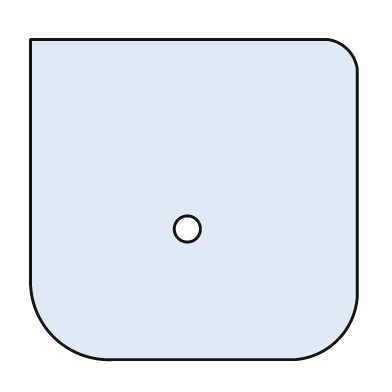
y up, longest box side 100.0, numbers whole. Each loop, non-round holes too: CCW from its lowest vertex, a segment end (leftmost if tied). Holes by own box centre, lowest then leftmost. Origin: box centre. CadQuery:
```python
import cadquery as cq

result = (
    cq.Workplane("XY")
    .moveTo(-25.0, -49.0)
    .lineTo(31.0, -49.0)
    .threePointArc((44.0, -43.0), (50.0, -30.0))
    .lineTo(50.0, 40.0)
    .threePointArc((47.0, 46.0), (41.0, 49.0))
    .lineTo(-50.0, 49.0)
    .lineTo(-50.0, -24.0)
    .threePointArc((-43.0, -42.0), (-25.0, -49.0))
    .close()
    .moveTo(-2.0, -9.0)
    .circle(4.0)
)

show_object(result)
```